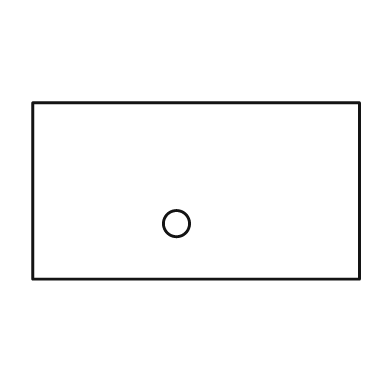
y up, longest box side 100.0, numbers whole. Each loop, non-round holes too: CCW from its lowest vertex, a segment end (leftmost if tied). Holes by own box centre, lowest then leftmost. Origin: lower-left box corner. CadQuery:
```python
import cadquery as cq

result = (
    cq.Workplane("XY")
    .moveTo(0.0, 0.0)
    .lineTo(100.0, 0.0)
    .lineTo(100.0, 54.0)
    .lineTo(0.0, 54.0)
    .close()
    .moveTo(44.0, 17.0)
    .circle(4.0)
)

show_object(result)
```